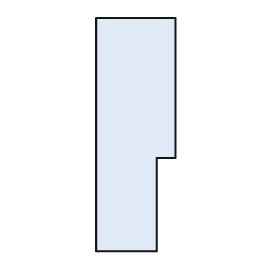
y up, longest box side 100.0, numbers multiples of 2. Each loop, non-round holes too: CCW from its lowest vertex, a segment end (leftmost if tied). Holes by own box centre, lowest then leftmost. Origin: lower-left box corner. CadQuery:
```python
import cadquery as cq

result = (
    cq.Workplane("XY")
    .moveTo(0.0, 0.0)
    .lineTo(26.0, 0.0)
    .lineTo(26.0, 40.0)
    .lineTo(34.0, 40.0)
    .lineTo(34.0, 100.0)
    .lineTo(0.0, 100.0)
    .close()
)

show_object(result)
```